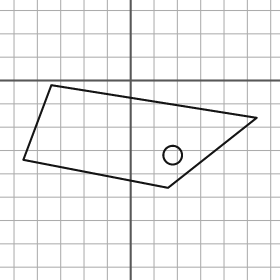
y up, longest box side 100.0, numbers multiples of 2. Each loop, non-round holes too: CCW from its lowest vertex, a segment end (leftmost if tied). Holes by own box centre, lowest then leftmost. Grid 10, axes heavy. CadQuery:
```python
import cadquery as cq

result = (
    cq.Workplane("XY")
    .moveTo(16.0, -46.0)
    .lineTo(54.0, -16.0)
    .lineTo(-34.0, -2.0)
    .lineTo(-46.0, -34.0)
    .close()
    .moveTo(18.0, -32.0)
    .circle(4.0)
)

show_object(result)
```